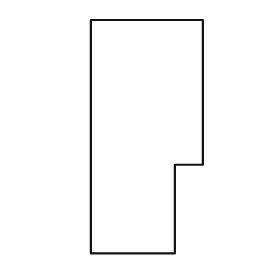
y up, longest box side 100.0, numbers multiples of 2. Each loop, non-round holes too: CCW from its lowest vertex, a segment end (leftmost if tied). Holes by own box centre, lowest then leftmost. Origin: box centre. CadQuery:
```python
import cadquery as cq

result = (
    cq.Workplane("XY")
    .moveTo(-24.0, -50.0)
    .lineTo(12.0, -50.0)
    .lineTo(12.0, -12.0)
    .lineTo(24.0, -12.0)
    .lineTo(24.0, 50.0)
    .lineTo(-24.0, 50.0)
    .close()
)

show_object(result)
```